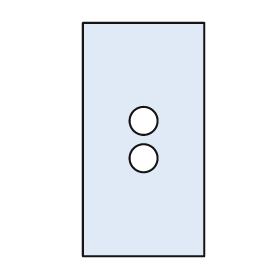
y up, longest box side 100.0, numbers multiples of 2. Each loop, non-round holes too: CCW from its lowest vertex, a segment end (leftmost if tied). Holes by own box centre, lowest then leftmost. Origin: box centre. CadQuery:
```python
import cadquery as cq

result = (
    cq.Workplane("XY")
    .moveTo(-26.0, -50.0)
    .lineTo(26.0, -50.0)
    .lineTo(26.0, 50.0)
    .lineTo(-26.0, 50.0)
    .close()
    .moveTo(0.0, -8.0)
    .circle(6.0)
    .moveTo(0.0, 8.0)
    .circle(6.0)
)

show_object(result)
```